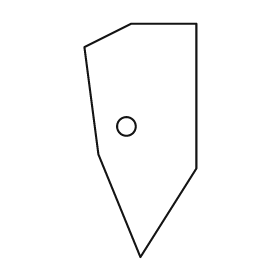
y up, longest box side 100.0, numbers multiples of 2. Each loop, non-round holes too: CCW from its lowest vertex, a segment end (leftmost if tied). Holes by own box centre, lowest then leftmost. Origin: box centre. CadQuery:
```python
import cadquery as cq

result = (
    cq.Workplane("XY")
    .moveTo(0.0, -50.0)
    .lineTo(24.0, -12.0)
    .lineTo(24.0, 50.0)
    .lineTo(-4.0, 50.0)
    .lineTo(-24.0, 40.0)
    .lineTo(-18.0, -6.0)
    .close()
    .moveTo(-6.0, 6.0)
    .circle(4.0)
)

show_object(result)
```